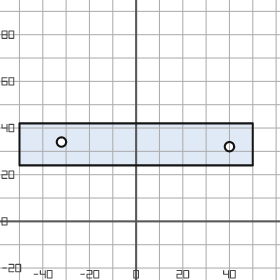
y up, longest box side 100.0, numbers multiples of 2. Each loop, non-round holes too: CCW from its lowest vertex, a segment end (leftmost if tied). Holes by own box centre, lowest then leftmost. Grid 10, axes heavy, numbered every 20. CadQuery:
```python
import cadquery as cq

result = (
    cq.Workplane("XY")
    .moveTo(-50.0, 24.0)
    .lineTo(50.0, 24.0)
    .lineTo(50.0, 42.0)
    .lineTo(-50.0, 42.0)
    .close()
    .moveTo(40.0, 32.0)
    .circle(2.0)
    .moveTo(-32.0, 34.0)
    .circle(2.0)
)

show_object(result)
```